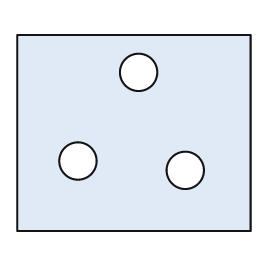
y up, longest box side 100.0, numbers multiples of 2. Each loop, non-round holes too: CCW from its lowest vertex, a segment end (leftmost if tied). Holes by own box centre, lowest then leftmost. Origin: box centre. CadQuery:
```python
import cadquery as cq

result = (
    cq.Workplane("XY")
    .moveTo(-50.0, -42.0)
    .lineTo(50.0, -42.0)
    .lineTo(50.0, 42.0)
    .lineTo(-50.0, 42.0)
    .close()
    .moveTo(22.0, -16.0)
    .circle(8.0)
    .moveTo(-24.0, -12.0)
    .circle(8.0)
    .moveTo(2.0, 26.0)
    .circle(8.0)
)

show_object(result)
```